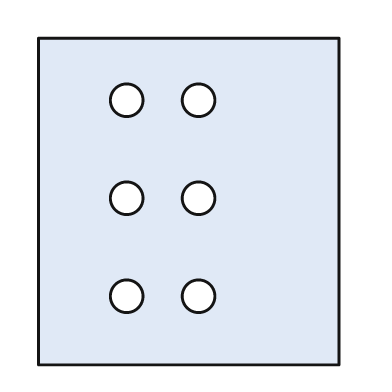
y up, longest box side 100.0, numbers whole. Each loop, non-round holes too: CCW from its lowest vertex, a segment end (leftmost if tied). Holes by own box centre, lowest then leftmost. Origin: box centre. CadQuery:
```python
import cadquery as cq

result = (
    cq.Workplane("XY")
    .moveTo(-46.0, -50.0)
    .lineTo(46.0, -50.0)
    .lineTo(46.0, 50.0)
    .lineTo(-46.0, 50.0)
    .close()
    .moveTo(-19.0, -29.0)
    .circle(5.0)
    .moveTo(3.0, -29.0)
    .circle(5.0)
    .moveTo(-19.0, 1.0)
    .circle(5.0)
    .moveTo(3.0, 1.0)
    .circle(5.0)
    .moveTo(-19.0, 31.0)
    .circle(5.0)
    .moveTo(3.0, 31.0)
    .circle(5.0)
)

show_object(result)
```